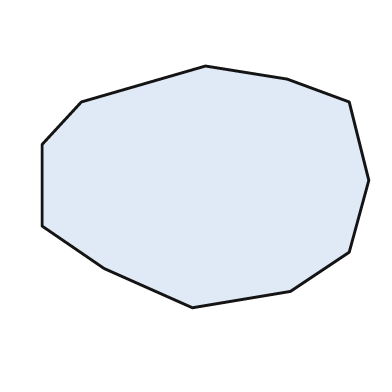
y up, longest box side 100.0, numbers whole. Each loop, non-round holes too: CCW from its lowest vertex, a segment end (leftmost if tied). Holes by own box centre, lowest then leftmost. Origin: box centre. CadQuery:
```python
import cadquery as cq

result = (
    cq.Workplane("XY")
    .moveTo(-4.0, -37.0)
    .lineTo(26.0, -32.0)
    .lineTo(44.0, -20.0)
    .lineTo(50.0, 2.0)
    .lineTo(44.0, 26.0)
    .lineTo(25.0, 33.0)
    .lineTo(0.0, 37.0)
    .lineTo(-38.0, 26.0)
    .lineTo(-50.0, 13.0)
    .lineTo(-50.0, -12.0)
    .lineTo(-31.0, -25.0)
    .close()
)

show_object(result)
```